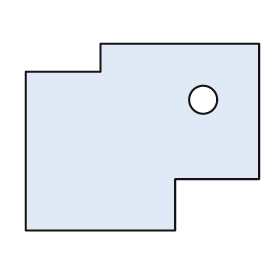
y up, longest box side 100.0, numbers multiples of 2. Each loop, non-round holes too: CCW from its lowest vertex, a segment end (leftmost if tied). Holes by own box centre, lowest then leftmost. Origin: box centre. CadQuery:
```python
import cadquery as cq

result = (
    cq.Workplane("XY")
    .moveTo(-50.0, -40.0)
    .lineTo(14.0, -40.0)
    .lineTo(14.0, -18.0)
    .lineTo(50.0, -18.0)
    .lineTo(50.0, 40.0)
    .lineTo(-18.0, 40.0)
    .lineTo(-18.0, 28.0)
    .lineTo(-50.0, 28.0)
    .close()
    .moveTo(26.0, 16.0)
    .circle(6.0)
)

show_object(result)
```